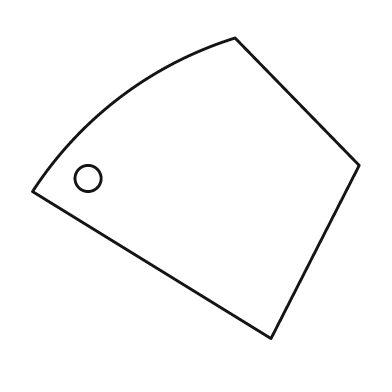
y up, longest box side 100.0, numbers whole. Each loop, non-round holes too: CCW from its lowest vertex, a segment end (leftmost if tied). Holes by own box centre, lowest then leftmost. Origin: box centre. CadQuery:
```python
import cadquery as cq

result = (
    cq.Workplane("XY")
    .moveTo(23.0, -46.0)
    .lineTo(50.0, 7.0)
    .lineTo(12.0, 46.0)
    .threePointArc((-23.0, 28.0), (-50.0, -1.0))
    .close()
    .moveTo(-33.0, 3.0)
    .circle(4.0)
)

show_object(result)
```